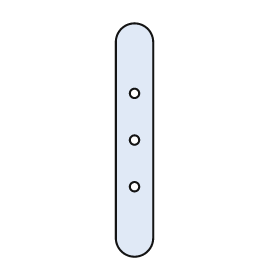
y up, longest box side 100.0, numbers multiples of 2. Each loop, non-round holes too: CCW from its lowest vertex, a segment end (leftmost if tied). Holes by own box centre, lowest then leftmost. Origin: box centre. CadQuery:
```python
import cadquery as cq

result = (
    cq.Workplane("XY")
    .moveTo(-8.0, -42.0)
    .threePointArc((0.0, -50.0), (8.0, -42.0))
    .lineTo(8.0, 42.0)
    .threePointArc((0.0, 50.0), (-8.0, 42.0))
    .close()
    .moveTo(0.0, -20.0)
    .circle(2.0)
    .moveTo(0.0, 0.0)
    .circle(2.0)
    .moveTo(0.0, 20.0)
    .circle(2.0)
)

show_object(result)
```